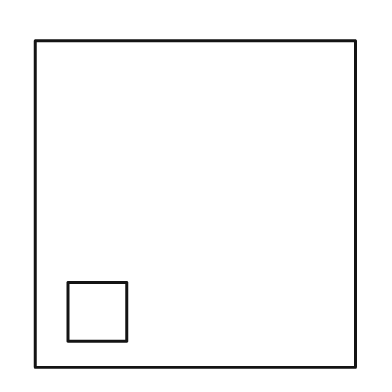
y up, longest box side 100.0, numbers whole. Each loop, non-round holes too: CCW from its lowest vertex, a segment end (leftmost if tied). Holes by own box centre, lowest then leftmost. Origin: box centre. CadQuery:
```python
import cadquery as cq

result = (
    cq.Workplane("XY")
    .moveTo(-49.0, -50.0)
    .lineTo(49.0, -50.0)
    .lineTo(49.0, 50.0)
    .lineTo(-49.0, 50.0)
    .close()
    .moveTo(-39.0, -42.0)
    .lineTo(-21.0, -42.0)
    .lineTo(-21.0, -24.0)
    .lineTo(-39.0, -24.0)
    .close()
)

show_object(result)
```